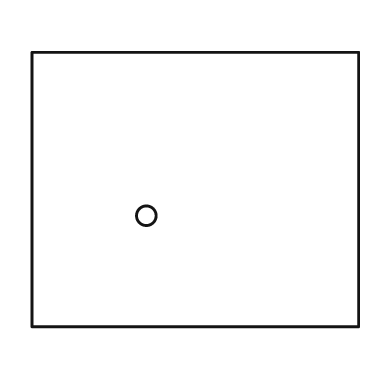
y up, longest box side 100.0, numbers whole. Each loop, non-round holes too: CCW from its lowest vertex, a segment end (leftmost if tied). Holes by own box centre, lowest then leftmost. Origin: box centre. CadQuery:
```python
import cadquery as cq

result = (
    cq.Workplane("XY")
    .moveTo(-50.0, -42.0)
    .lineTo(50.0, -42.0)
    .lineTo(50.0, 42.0)
    .lineTo(-50.0, 42.0)
    .close()
    .moveTo(-15.0, -8.0)
    .circle(3.0)
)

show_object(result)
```